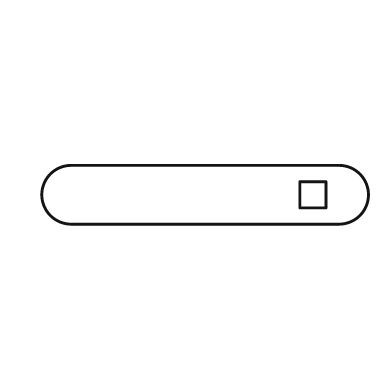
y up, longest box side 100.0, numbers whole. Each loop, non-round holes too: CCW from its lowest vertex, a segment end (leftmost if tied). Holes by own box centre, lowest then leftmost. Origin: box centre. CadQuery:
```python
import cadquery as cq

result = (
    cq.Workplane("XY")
    .moveTo(-41.0, -9.0)
    .lineTo(41.0, -9.0)
    .threePointArc((50.0, 0.0), (41.0, 9.0))
    .lineTo(-41.0, 9.0)
    .threePointArc((-50.0, 0.0), (-41.0, -9.0))
    .close()
    .moveTo(29.0, -4.0)
    .lineTo(37.0, -4.0)
    .lineTo(37.0, 4.0)
    .lineTo(29.0, 4.0)
    .close()
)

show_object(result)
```